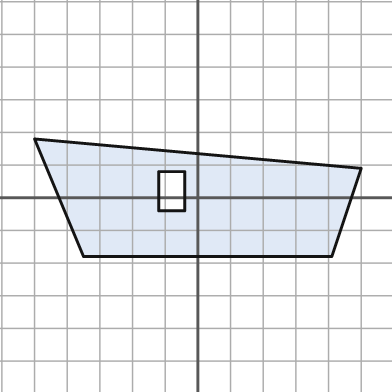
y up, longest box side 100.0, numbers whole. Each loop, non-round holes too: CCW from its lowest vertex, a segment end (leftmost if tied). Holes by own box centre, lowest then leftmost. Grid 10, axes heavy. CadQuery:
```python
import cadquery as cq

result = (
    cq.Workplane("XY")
    .moveTo(-35.0, -18.0)
    .lineTo(41.0, -18.0)
    .lineTo(50.0, 9.0)
    .lineTo(-50.0, 18.0)
    .close()
    .moveTo(-12.0, -4.0)
    .lineTo(-4.0, -4.0)
    .lineTo(-4.0, 8.0)
    .lineTo(-12.0, 8.0)
    .close()
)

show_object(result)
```